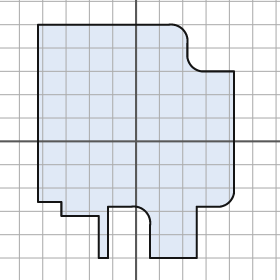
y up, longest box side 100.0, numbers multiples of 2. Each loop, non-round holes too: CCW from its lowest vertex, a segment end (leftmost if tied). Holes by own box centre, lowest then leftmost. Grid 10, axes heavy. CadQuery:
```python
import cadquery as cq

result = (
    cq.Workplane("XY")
    .moveTo(-16.0, -50.0)
    .lineTo(-12.0, -50.0)
    .lineTo(-12.0, -28.0)
    .lineTo(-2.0, -28.0)
    .threePointArc((4.0, -30.0), (6.0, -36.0))
    .lineTo(6.0, -50.0)
    .lineTo(26.0, -50.0)
    .lineTo(26.0, -28.0)
    .lineTo(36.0, -28.0)
    .threePointArc((40.0, -26.0), (42.0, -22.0))
    .lineTo(42.0, 30.0)
    .lineTo(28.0, 30.0)
    .threePointArc((24.0, 32.0), (22.0, 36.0))
    .lineTo(22.0, 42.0)
    .threePointArc((20.0, 48.0), (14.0, 50.0))
    .lineTo(-42.0, 50.0)
    .lineTo(-42.0, -26.0)
    .lineTo(-32.0, -26.0)
    .lineTo(-32.0, -32.0)
    .lineTo(-16.0, -32.0)
    .close()
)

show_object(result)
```